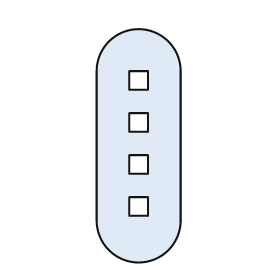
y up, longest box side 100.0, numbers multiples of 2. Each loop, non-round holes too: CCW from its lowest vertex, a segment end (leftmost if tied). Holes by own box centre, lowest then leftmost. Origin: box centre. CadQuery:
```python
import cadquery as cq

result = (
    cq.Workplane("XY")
    .moveTo(-18.0, -32.0)
    .threePointArc((0.0, -50.0), (18.0, -32.0))
    .lineTo(18.0, 32.0)
    .threePointArc((0.0, 50.0), (-18.0, 32.0))
    .close()
    .moveTo(-4.0, -30.0)
    .lineTo(4.0, -30.0)
    .lineTo(4.0, -22.0)
    .lineTo(-4.0, -22.0)
    .close()
    .moveTo(-4.0, -12.0)
    .lineTo(4.0, -12.0)
    .lineTo(4.0, -4.0)
    .lineTo(-4.0, -4.0)
    .close()
    .moveTo(-4.0, 6.0)
    .lineTo(4.0, 6.0)
    .lineTo(4.0, 14.0)
    .lineTo(-4.0, 14.0)
    .close()
    .moveTo(-4.0, 24.0)
    .lineTo(4.0, 24.0)
    .lineTo(4.0, 32.0)
    .lineTo(-4.0, 32.0)
    .close()
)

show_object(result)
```